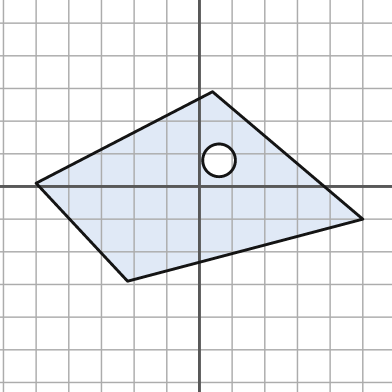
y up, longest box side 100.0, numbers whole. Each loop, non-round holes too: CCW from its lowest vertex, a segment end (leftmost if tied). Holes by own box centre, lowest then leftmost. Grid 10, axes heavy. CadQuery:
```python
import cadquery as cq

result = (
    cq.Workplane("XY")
    .moveTo(-22.0, -29.0)
    .lineTo(50.0, -10.0)
    .lineTo(4.0, 29.0)
    .lineTo(-50.0, 1.0)
    .close()
    .moveTo(6.0, 8.0)
    .circle(5.0)
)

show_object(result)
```